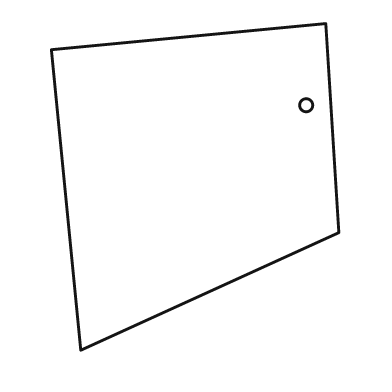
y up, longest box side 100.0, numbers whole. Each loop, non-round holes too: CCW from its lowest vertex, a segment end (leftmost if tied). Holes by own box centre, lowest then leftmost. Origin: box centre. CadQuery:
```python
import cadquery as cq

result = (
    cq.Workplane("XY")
    .moveTo(-35.0, -50.0)
    .lineTo(44.0, -14.0)
    .lineTo(40.0, 50.0)
    .lineTo(-44.0, 42.0)
    .close()
    .moveTo(34.0, 25.0)
    .circle(2.0)
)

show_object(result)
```